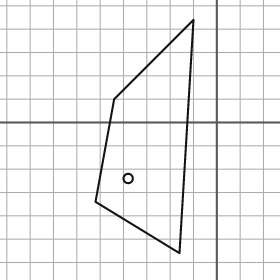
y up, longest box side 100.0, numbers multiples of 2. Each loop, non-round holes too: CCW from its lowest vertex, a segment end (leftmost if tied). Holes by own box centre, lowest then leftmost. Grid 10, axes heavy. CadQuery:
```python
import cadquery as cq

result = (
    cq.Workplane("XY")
    .moveTo(-16.0, -56.0)
    .lineTo(-10.0, 44.0)
    .lineTo(-44.0, 10.0)
    .lineTo(-52.0, -34.0)
    .close()
    .moveTo(-38.0, -24.0)
    .circle(2.0)
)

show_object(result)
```